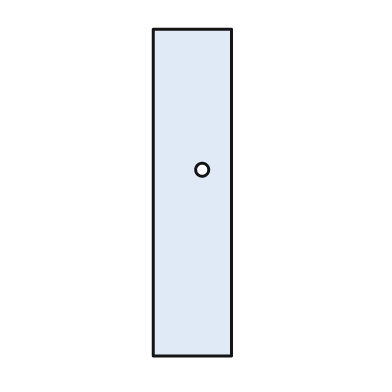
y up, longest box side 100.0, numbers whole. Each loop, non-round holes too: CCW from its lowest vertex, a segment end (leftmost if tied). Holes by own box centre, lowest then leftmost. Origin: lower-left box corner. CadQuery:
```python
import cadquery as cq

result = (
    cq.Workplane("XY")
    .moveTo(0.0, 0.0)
    .lineTo(24.0, 0.0)
    .lineTo(24.0, 100.0)
    .lineTo(0.0, 100.0)
    .close()
    .moveTo(15.0, 57.0)
    .circle(2.0)
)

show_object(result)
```